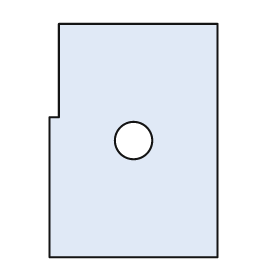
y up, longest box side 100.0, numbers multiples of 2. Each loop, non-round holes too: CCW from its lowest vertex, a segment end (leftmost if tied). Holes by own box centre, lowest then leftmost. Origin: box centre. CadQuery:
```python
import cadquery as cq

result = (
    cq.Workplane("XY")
    .moveTo(-36.0, -50.0)
    .lineTo(36.0, -50.0)
    .lineTo(36.0, 50.0)
    .lineTo(-32.0, 50.0)
    .lineTo(-32.0, 10.0)
    .lineTo(-36.0, 10.0)
    .close()
    .moveTo(0.0, 0.0)
    .circle(8.0)
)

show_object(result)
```